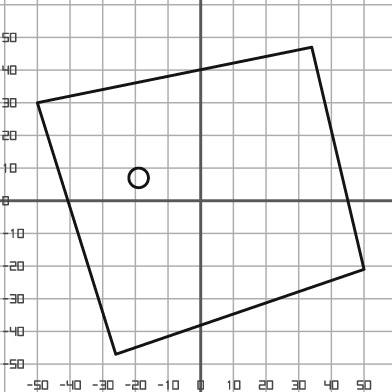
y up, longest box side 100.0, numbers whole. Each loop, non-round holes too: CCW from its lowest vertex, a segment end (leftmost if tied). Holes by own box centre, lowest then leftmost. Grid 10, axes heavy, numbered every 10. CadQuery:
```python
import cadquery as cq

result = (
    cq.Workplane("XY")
    .moveTo(-26.0, -47.0)
    .lineTo(50.0, -21.0)
    .lineTo(34.0, 47.0)
    .lineTo(-50.0, 30.0)
    .close()
    .moveTo(-19.0, 7.0)
    .circle(3.0)
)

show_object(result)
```